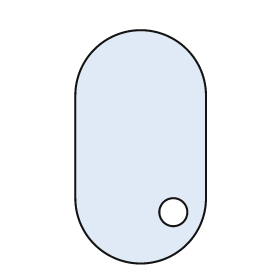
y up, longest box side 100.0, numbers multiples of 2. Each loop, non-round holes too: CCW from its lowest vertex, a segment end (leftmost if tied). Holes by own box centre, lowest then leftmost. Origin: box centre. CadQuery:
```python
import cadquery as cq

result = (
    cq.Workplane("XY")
    .moveTo(-28.0, -22.0)
    .threePointArc((0.0, -50.0), (28.0, -22.0))
    .lineTo(28.0, 22.0)
    .threePointArc((0.0, 50.0), (-28.0, 22.0))
    .close()
    .moveTo(14.0, -28.0)
    .circle(6.0)
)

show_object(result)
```